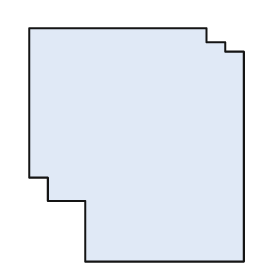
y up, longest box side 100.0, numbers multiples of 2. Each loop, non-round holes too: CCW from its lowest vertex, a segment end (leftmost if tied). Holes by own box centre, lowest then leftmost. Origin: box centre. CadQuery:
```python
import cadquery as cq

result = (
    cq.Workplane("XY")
    .moveTo(-22.0, -50.0)
    .lineTo(46.0, -50.0)
    .lineTo(46.0, 40.0)
    .lineTo(38.0, 40.0)
    .lineTo(38.0, 44.0)
    .lineTo(30.0, 44.0)
    .lineTo(30.0, 50.0)
    .lineTo(-46.0, 50.0)
    .lineTo(-46.0, -14.0)
    .lineTo(-38.0, -14.0)
    .lineTo(-38.0, -24.0)
    .lineTo(-22.0, -24.0)
    .close()
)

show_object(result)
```